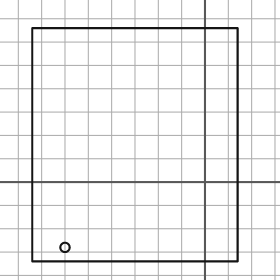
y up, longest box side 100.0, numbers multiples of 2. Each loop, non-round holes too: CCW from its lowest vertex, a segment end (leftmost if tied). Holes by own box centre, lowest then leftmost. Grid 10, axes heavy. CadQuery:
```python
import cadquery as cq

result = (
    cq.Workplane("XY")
    .moveTo(-74.0, -34.0)
    .lineTo(14.0, -34.0)
    .lineTo(14.0, 66.0)
    .lineTo(-74.0, 66.0)
    .close()
    .moveTo(-60.0, -28.0)
    .circle(2.0)
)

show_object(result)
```